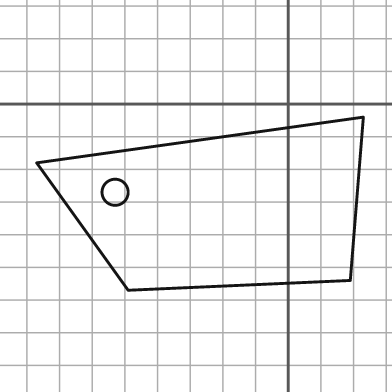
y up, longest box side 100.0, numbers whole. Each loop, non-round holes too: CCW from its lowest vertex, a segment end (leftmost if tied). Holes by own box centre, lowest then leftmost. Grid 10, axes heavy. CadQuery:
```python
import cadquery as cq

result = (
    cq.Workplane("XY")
    .moveTo(-49.0, -57.0)
    .lineTo(19.0, -54.0)
    .lineTo(23.0, -4.0)
    .lineTo(-77.0, -18.0)
    .close()
    .moveTo(-53.0, -27.0)
    .circle(4.0)
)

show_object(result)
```